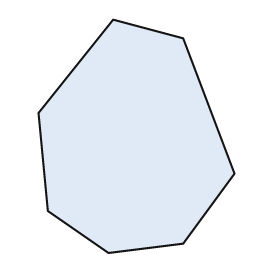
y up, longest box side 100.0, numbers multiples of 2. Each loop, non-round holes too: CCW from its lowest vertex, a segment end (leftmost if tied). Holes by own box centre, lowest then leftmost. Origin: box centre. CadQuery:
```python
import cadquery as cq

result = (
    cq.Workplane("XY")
    .moveTo(-12.0, -50.0)
    .lineTo(20.0, -46.0)
    .lineTo(42.0, -16.0)
    .lineTo(20.0, 42.0)
    .lineTo(-10.0, 50.0)
    .lineTo(-42.0, 10.0)
    .lineTo(-38.0, -32.0)
    .close()
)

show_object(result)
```